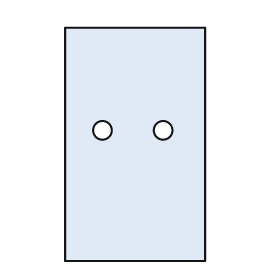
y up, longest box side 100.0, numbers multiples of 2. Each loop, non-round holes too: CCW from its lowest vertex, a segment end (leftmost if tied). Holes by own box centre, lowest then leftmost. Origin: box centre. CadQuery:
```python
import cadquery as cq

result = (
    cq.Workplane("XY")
    .moveTo(-30.0, -50.0)
    .lineTo(30.0, -50.0)
    .lineTo(30.0, 50.0)
    .lineTo(-30.0, 50.0)
    .close()
    .moveTo(-14.0, 6.0)
    .circle(4.0)
    .moveTo(12.0, 6.0)
    .circle(4.0)
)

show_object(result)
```